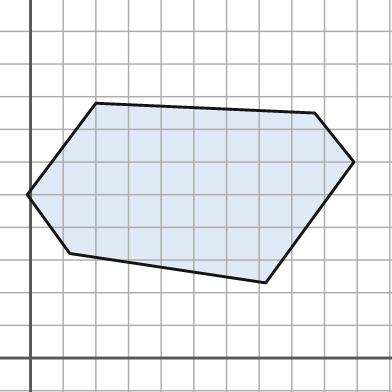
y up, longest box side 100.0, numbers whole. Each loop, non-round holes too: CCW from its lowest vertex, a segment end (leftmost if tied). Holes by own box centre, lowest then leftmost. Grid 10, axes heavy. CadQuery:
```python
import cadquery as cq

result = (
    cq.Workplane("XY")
    .moveTo(72.0, 23.0)
    .lineTo(99.0, 60.0)
    .lineTo(87.0, 75.0)
    .lineTo(20.0, 78.0)
    .lineTo(-1.0, 50.0)
    .lineTo(12.0, 32.0)
    .close()
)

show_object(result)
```